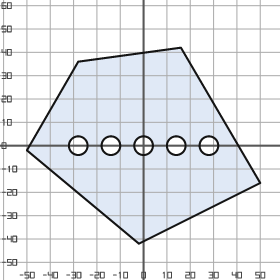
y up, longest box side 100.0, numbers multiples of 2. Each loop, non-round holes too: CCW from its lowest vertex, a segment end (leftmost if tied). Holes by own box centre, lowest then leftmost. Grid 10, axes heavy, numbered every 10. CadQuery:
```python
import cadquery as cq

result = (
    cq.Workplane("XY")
    .moveTo(-2.0, -42.0)
    .lineTo(50.0, -16.0)
    .lineTo(16.0, 42.0)
    .lineTo(-28.0, 36.0)
    .lineTo(-50.0, -2.0)
    .close()
    .moveTo(-28.0, 0.0)
    .circle(4.0)
    .moveTo(-14.0, 0.0)
    .circle(4.0)
    .moveTo(0.0, 0.0)
    .circle(4.0)
    .moveTo(14.0, 0.0)
    .circle(4.0)
    .moveTo(28.0, 0.0)
    .circle(4.0)
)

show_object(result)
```